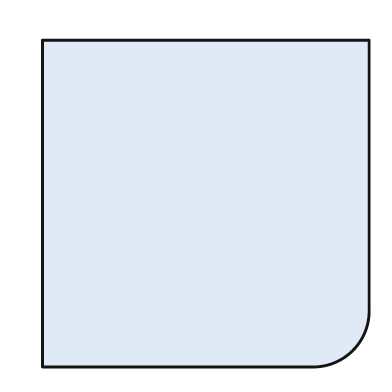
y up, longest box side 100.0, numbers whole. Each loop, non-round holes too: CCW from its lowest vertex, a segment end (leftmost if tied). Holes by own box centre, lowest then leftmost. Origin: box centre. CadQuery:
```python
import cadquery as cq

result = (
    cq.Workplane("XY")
    .moveTo(-50.0, -50.0)
    .lineTo(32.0, -50.0)
    .threePointArc((45.0, -45.0), (50.0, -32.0))
    .lineTo(50.0, 50.0)
    .lineTo(-50.0, 50.0)
    .close()
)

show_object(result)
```